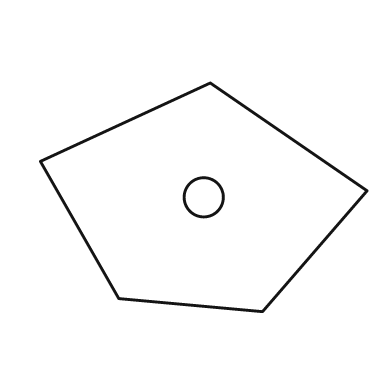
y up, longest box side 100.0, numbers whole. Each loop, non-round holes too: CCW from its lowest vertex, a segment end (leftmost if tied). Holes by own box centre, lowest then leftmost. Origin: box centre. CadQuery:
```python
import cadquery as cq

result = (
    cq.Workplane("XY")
    .moveTo(18.0, -35.0)
    .lineTo(50.0, 2.0)
    .lineTo(2.0, 35.0)
    .lineTo(-50.0, 11.0)
    .lineTo(-26.0, -31.0)
    .close()
    .moveTo(0.0, 0.0)
    .circle(6.0)
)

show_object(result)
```